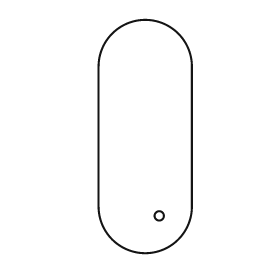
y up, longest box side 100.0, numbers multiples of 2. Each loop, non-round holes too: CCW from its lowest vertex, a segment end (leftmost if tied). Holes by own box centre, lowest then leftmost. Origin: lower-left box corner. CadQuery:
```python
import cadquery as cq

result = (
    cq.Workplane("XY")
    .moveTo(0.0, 20.0)
    .threePointArc((20.0, 0.0), (40.0, 20.0))
    .lineTo(40.0, 80.0)
    .threePointArc((20.0, 100.0), (0.0, 80.0))
    .close()
    .moveTo(26.0, 16.0)
    .circle(2.0)
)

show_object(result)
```